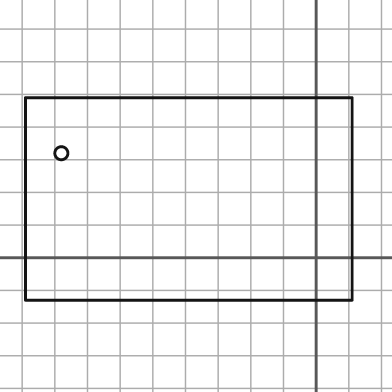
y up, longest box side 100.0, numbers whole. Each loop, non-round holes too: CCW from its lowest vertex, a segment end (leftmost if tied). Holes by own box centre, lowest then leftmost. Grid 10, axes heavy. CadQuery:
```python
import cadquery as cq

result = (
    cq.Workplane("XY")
    .moveTo(-89.0, -13.0)
    .lineTo(11.0, -13.0)
    .lineTo(11.0, 49.0)
    .lineTo(-89.0, 49.0)
    .close()
    .moveTo(-78.0, 32.0)
    .circle(2.0)
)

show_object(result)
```